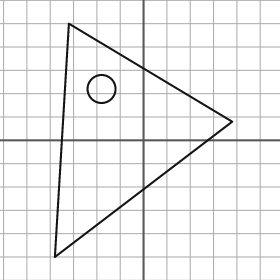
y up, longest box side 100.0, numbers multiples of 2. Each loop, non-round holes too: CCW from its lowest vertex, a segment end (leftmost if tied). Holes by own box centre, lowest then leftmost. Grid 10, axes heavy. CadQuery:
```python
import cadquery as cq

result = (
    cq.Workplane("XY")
    .moveTo(-38.0, -50.0)
    .lineTo(38.0, 8.0)
    .lineTo(-32.0, 50.0)
    .close()
    .moveTo(-18.0, 22.0)
    .circle(6.0)
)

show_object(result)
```